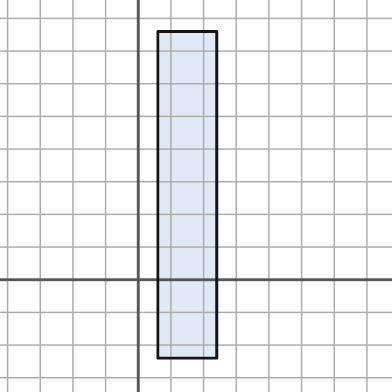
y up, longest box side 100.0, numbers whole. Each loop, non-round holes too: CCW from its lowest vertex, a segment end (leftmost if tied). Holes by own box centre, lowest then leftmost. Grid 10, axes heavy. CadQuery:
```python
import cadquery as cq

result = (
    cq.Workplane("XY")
    .moveTo(6.0, -24.0)
    .lineTo(24.0, -24.0)
    .lineTo(24.0, 76.0)
    .lineTo(6.0, 76.0)
    .close()
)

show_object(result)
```